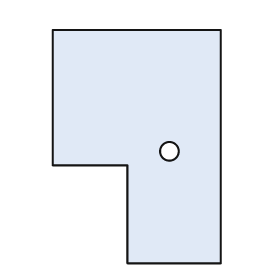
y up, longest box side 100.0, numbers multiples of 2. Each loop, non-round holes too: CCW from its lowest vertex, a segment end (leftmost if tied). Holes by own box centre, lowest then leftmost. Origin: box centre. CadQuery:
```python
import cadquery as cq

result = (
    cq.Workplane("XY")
    .moveTo(-4.0, -50.0)
    .lineTo(36.0, -50.0)
    .lineTo(36.0, 50.0)
    .lineTo(-36.0, 50.0)
    .lineTo(-36.0, -8.0)
    .lineTo(-4.0, -8.0)
    .close()
    .moveTo(14.0, -2.0)
    .circle(4.0)
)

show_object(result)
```